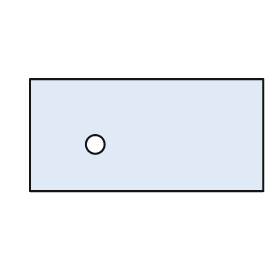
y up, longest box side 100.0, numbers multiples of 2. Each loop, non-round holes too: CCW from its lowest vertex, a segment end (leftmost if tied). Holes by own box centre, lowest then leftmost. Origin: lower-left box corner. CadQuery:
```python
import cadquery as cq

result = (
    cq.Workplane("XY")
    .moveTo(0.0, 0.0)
    .lineTo(100.0, 0.0)
    .lineTo(100.0, 48.0)
    .lineTo(0.0, 48.0)
    .close()
    .moveTo(28.0, 20.0)
    .circle(4.0)
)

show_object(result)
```